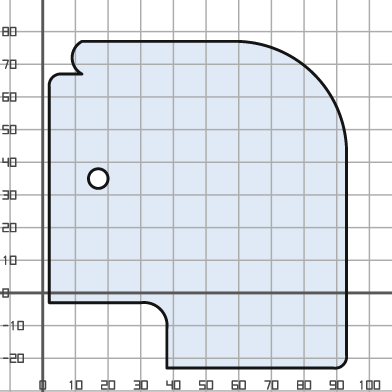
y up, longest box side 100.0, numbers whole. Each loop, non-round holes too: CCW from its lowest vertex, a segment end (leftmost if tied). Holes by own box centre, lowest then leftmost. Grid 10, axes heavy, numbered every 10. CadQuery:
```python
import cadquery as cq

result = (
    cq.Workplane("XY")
    .moveTo(38.0, -23.0)
    .lineTo(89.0, -23.0)
    .threePointArc((92.0, -22.0), (93.0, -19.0))
    .lineTo(93.0, 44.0)
    .threePointArc((83.0, 67.0), (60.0, 77.0))
    .lineTo(12.0, 77.0)
    .threePointArc((9.0, 72.0), (12.0, 67.0))
    .lineTo(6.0, 67.0)
    .threePointArc((3.0, 66.0), (2.0, 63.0))
    .lineTo(2.0, -3.0)
    .lineTo(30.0, -3.0)
    .threePointArc((36.0, -5.0), (38.0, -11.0))
    .close()
    .moveTo(17.0, 35.0)
    .circle(3.0)
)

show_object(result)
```